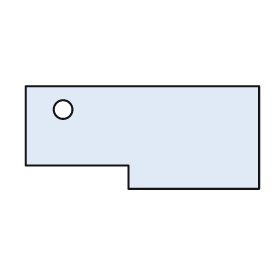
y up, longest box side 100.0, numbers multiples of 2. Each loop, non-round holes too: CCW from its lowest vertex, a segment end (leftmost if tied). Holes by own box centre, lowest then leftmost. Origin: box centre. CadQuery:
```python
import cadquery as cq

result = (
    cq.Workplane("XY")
    .moveTo(-6.0, -22.0)
    .lineTo(50.0, -22.0)
    .lineTo(50.0, 22.0)
    .lineTo(-50.0, 22.0)
    .lineTo(-50.0, -12.0)
    .lineTo(-6.0, -12.0)
    .close()
    .moveTo(-34.0, 12.0)
    .circle(4.0)
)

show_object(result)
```